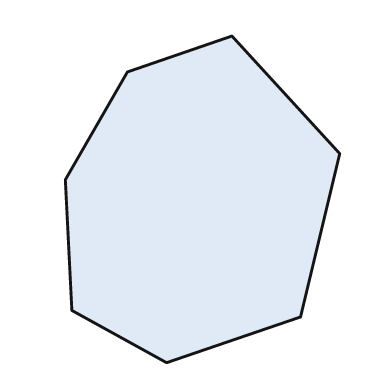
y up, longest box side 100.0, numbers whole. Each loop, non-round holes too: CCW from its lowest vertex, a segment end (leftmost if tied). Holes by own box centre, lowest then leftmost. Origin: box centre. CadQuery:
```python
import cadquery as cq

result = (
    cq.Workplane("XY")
    .moveTo(-11.0, -50.0)
    .lineTo(30.0, -36.0)
    .lineTo(42.0, 14.0)
    .lineTo(9.0, 50.0)
    .lineTo(-23.0, 39.0)
    .lineTo(-42.0, 6.0)
    .lineTo(-40.0, -34.0)
    .close()
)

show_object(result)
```